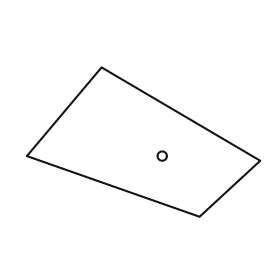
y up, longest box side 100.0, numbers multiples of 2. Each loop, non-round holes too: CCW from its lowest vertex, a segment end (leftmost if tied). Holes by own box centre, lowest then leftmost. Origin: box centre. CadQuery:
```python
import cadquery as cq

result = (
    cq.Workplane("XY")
    .moveTo(24.0, -32.0)
    .lineTo(50.0, -8.0)
    .lineTo(-18.0, 32.0)
    .lineTo(-50.0, -6.0)
    .close()
    .moveTo(8.0, -6.0)
    .circle(2.0)
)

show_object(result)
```